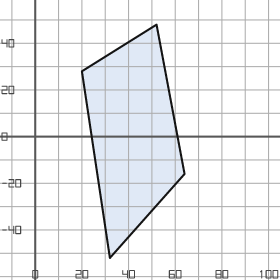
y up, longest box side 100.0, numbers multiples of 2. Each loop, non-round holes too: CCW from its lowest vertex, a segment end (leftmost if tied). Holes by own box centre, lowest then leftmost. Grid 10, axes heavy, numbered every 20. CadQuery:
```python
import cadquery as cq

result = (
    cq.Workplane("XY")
    .moveTo(32.0, -52.0)
    .lineTo(64.0, -16.0)
    .lineTo(52.0, 48.0)
    .lineTo(20.0, 28.0)
    .close()
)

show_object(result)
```